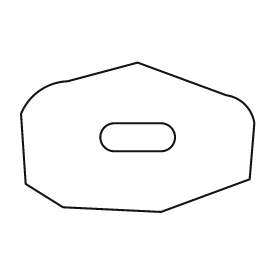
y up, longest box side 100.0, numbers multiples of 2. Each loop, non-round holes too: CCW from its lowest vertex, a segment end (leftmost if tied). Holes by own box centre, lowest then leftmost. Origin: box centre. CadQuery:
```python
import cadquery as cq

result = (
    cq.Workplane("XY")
    .moveTo(10.0, -32.0)
    .lineTo(48.0, -18.0)
    .lineTo(50.0, 6.0)
    .threePointArc((46.0, 14.0), (38.0, 18.0))
    .lineTo(0.0, 32.0)
    .lineTo(-30.0, 24.0)
    .threePointArc((-42.0, 20.0), (-50.0, 10.0))
    .lineTo(-48.0, -20.0)
    .lineTo(-32.0, -30.0)
    .close()
    .moveTo(-10.0, -6.0)
    .lineTo(10.0, -6.0)
    .threePointArc((16.0, 0.0), (10.0, 6.0))
    .lineTo(-10.0, 6.0)
    .threePointArc((-16.0, 0.0), (-10.0, -6.0))
    .close()
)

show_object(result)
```